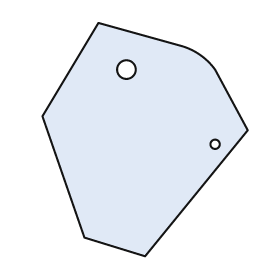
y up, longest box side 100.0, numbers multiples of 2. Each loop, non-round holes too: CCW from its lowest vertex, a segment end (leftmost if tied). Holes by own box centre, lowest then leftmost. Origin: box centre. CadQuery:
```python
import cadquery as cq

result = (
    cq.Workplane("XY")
    .moveTo(0.0, -50.0)
    .lineTo(44.0, 4.0)
    .lineTo(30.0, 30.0)
    .threePointArc((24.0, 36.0), (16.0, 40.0))
    .lineTo(-20.0, 50.0)
    .lineTo(-44.0, 10.0)
    .lineTo(-26.0, -42.0)
    .close()
    .moveTo(30.0, -2.0)
    .circle(2.0)
    .moveTo(-8.0, 30.0)
    .circle(4.0)
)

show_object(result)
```